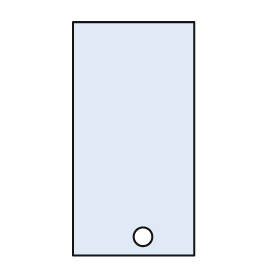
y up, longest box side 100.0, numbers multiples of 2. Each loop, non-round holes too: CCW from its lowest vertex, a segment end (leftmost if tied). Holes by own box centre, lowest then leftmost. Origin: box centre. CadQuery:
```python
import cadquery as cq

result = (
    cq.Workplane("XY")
    .moveTo(-26.0, -50.0)
    .lineTo(26.0, -50.0)
    .lineTo(26.0, 50.0)
    .lineTo(-26.0, 50.0)
    .close()
    .moveTo(4.0, -42.0)
    .circle(4.0)
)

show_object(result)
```